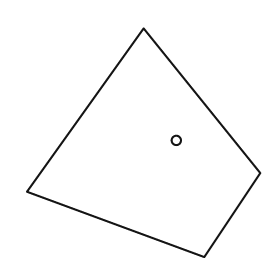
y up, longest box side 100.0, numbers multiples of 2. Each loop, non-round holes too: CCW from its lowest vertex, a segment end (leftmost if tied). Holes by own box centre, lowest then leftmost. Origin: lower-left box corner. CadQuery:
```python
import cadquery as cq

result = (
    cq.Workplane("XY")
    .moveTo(76.0, 0.0)
    .lineTo(100.0, 36.0)
    .lineTo(50.0, 98.0)
    .lineTo(0.0, 28.0)
    .close()
    .moveTo(64.0, 50.0)
    .circle(2.0)
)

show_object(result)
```